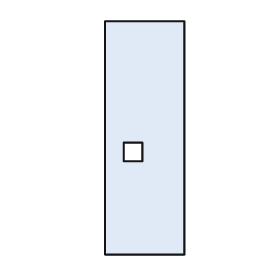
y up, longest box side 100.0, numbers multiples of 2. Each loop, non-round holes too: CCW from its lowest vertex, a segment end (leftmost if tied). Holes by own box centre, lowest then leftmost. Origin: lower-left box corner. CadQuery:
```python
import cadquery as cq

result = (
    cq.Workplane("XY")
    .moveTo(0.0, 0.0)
    .lineTo(34.0, 0.0)
    .lineTo(34.0, 100.0)
    .lineTo(0.0, 100.0)
    .close()
    .moveTo(8.0, 40.0)
    .lineTo(16.0, 40.0)
    .lineTo(16.0, 48.0)
    .lineTo(8.0, 48.0)
    .close()
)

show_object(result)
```